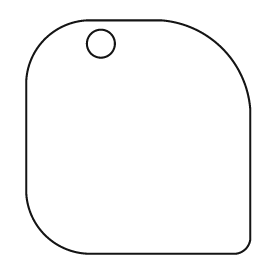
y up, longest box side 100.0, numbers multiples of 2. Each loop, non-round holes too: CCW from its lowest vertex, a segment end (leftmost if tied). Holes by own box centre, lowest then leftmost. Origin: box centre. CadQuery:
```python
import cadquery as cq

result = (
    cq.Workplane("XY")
    .moveTo(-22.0, -50.0)
    .lineTo(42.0, -50.0)
    .threePointArc((46.0, -48.0), (48.0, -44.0))
    .lineTo(48.0, 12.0)
    .threePointArc((36.0, 38.0), (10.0, 50.0))
    .lineTo(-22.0, 50.0)
    .threePointArc((-40.0, 42.0), (-48.0, 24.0))
    .lineTo(-48.0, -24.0)
    .threePointArc((-40.0, -42.0), (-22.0, -50.0))
    .close()
    .moveTo(-16.0, 40.0)
    .circle(6.0)
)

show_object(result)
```